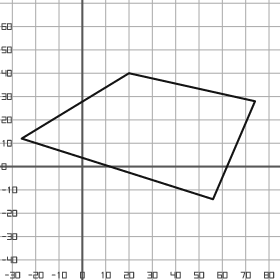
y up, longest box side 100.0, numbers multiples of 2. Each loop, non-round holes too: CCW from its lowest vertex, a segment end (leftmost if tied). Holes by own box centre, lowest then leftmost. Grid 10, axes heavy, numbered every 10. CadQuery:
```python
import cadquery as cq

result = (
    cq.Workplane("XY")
    .moveTo(56.0, -14.0)
    .lineTo(74.0, 28.0)
    .lineTo(20.0, 40.0)
    .lineTo(-26.0, 12.0)
    .close()
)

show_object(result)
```